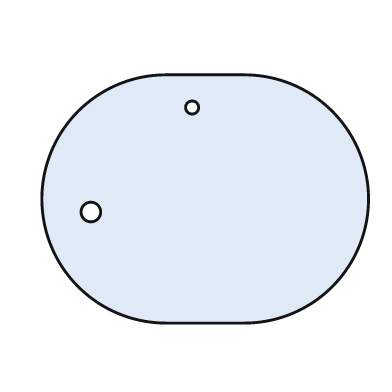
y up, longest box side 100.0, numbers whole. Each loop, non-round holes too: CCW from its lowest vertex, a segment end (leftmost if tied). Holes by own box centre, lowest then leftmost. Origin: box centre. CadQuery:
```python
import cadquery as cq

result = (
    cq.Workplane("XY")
    .moveTo(-12.0, -38.0)
    .lineTo(12.0, -38.0)
    .threePointArc((50.0, 0.0), (12.0, 38.0))
    .lineTo(-12.0, 38.0)
    .threePointArc((-50.0, 0.0), (-12.0, -38.0))
    .close()
    .moveTo(-35.0, -4.0)
    .circle(3.0)
    .moveTo(-4.0, 28.0)
    .circle(2.0)
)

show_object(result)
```